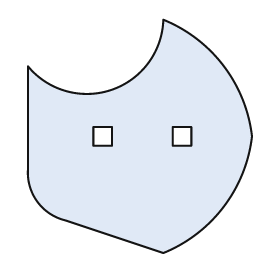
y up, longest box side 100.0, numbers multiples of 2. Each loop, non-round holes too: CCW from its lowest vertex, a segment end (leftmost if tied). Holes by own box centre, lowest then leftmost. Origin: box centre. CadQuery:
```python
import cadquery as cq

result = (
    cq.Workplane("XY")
    .moveTo(10.0, -50.0)
    .threePointArc((36.0, -30.0), (48.0, 0.0))
    .threePointArc((36.0, 30.0), (10.0, 50.0))
    .threePointArc((-12.0, 20.0), (-48.0, 30.0))
    .lineTo(-48.0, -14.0)
    .threePointArc((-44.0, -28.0), (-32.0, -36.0))
    .close()
    .moveTo(-20.0, -4.0)
    .lineTo(-12.0, -4.0)
    .lineTo(-12.0, 4.0)
    .lineTo(-20.0, 4.0)
    .close()
    .moveTo(14.0, -4.0)
    .lineTo(22.0, -4.0)
    .lineTo(22.0, 4.0)
    .lineTo(14.0, 4.0)
    .close()
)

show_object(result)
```